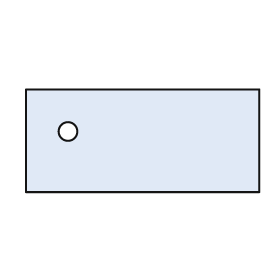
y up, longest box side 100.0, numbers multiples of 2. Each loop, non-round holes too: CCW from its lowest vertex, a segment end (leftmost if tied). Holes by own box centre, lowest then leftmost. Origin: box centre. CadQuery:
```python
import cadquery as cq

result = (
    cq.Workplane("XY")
    .moveTo(-50.0, -22.0)
    .lineTo(50.0, -22.0)
    .lineTo(50.0, 22.0)
    .lineTo(-50.0, 22.0)
    .close()
    .moveTo(-32.0, 4.0)
    .circle(4.0)
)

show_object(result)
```